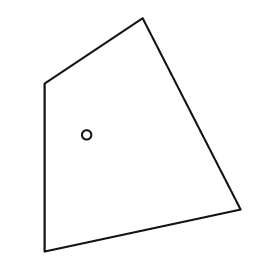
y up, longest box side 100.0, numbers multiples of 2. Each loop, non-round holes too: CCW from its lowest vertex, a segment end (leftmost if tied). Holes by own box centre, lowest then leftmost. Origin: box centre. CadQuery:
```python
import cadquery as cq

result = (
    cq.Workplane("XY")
    .moveTo(-42.0, -50.0)
    .lineTo(42.0, -32.0)
    .lineTo(0.0, 50.0)
    .lineTo(-42.0, 22.0)
    .close()
    .moveTo(-24.0, 0.0)
    .circle(2.0)
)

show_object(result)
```